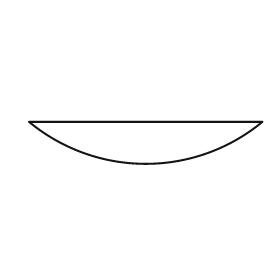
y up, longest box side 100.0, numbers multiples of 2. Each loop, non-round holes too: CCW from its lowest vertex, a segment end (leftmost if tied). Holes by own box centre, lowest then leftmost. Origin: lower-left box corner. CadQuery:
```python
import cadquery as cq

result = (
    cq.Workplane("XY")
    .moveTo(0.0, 18.0)
    .threePointArc((50.0, 0.0), (100.0, 18.0))
    .close()
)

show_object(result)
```